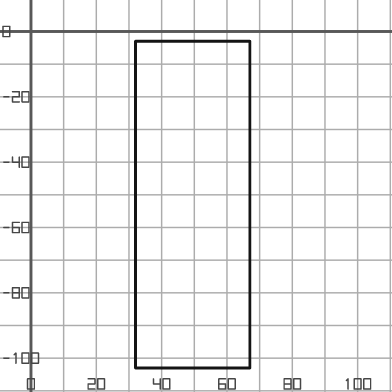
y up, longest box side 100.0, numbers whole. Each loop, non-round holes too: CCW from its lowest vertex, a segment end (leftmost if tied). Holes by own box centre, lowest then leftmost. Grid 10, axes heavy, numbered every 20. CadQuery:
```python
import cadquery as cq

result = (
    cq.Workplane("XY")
    .moveTo(32.0, -103.0)
    .lineTo(67.0, -103.0)
    .lineTo(67.0, -3.0)
    .lineTo(32.0, -3.0)
    .close()
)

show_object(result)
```